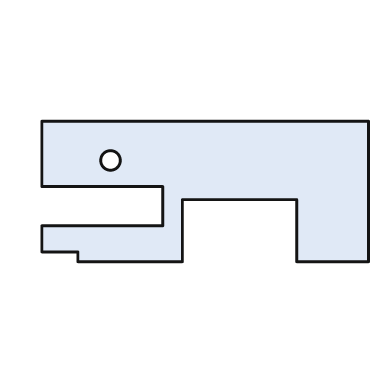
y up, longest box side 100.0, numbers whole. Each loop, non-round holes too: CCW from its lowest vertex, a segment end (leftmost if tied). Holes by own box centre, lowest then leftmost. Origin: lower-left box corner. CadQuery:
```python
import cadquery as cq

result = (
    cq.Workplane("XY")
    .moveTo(11.0, 0.0)
    .lineTo(43.0, 0.0)
    .lineTo(43.0, 19.0)
    .lineTo(78.0, 19.0)
    .lineTo(78.0, 0.0)
    .lineTo(100.0, 0.0)
    .lineTo(100.0, 43.0)
    .lineTo(0.0, 43.0)
    .lineTo(0.0, 23.0)
    .lineTo(37.0, 23.0)
    .lineTo(37.0, 11.0)
    .lineTo(0.0, 11.0)
    .lineTo(0.0, 3.0)
    .lineTo(11.0, 3.0)
    .close()
    .moveTo(21.0, 31.0)
    .circle(3.0)
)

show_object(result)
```